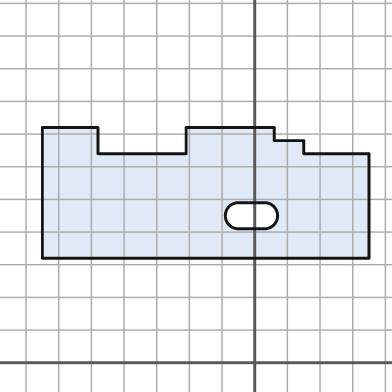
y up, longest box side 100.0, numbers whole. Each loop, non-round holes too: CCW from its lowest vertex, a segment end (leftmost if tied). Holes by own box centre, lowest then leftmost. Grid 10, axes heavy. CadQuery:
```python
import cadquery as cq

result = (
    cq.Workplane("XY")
    .moveTo(-65.0, 32.0)
    .lineTo(35.0, 32.0)
    .lineTo(35.0, 64.0)
    .lineTo(15.0, 64.0)
    .lineTo(15.0, 68.0)
    .lineTo(6.0, 68.0)
    .lineTo(6.0, 72.0)
    .lineTo(-21.0, 72.0)
    .lineTo(-21.0, 64.0)
    .lineTo(-48.0, 64.0)
    .lineTo(-48.0, 72.0)
    .lineTo(-65.0, 72.0)
    .close()
    .moveTo(-5.0, 41.0)
    .lineTo(3.0, 41.0)
    .threePointArc((7.0, 45.0), (3.0, 49.0))
    .lineTo(-5.0, 49.0)
    .threePointArc((-9.0, 45.0), (-5.0, 41.0))
    .close()
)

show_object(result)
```